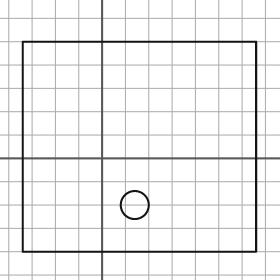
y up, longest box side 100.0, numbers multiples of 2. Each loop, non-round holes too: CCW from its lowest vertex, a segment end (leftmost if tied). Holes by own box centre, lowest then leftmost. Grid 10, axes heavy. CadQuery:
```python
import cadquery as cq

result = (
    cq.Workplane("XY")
    .moveTo(-34.0, -40.0)
    .lineTo(66.0, -40.0)
    .lineTo(66.0, 50.0)
    .lineTo(-34.0, 50.0)
    .close()
    .moveTo(14.0, -20.0)
    .circle(6.0)
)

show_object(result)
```